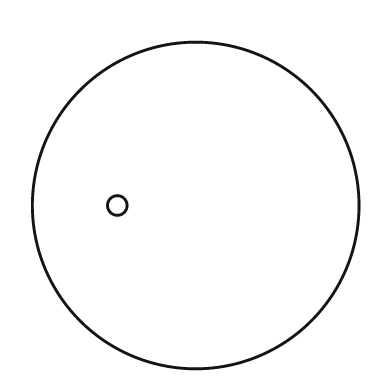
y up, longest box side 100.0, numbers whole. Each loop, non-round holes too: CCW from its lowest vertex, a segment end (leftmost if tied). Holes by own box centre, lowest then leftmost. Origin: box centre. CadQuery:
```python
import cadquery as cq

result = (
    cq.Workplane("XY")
    .moveTo(0.0, 0.0)
    .circle(50.0)
    .moveTo(-24.0, 0.0)
    .circle(3.0)
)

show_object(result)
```